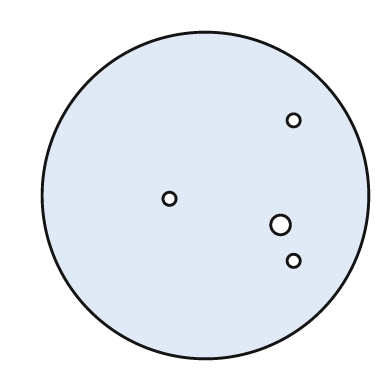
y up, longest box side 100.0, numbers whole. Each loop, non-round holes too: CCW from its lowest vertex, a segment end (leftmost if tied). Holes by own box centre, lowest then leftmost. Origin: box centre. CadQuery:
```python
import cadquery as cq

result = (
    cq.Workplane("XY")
    .moveTo(0.0, 0.0)
    .circle(50.0)
    .moveTo(27.0, -20.0)
    .circle(2.0)
    .moveTo(23.0, -9.0)
    .circle(3.0)
    .moveTo(-11.0, -1.0)
    .circle(2.0)
    .moveTo(27.0, 23.0)
    .circle(2.0)
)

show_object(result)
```